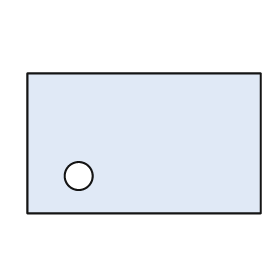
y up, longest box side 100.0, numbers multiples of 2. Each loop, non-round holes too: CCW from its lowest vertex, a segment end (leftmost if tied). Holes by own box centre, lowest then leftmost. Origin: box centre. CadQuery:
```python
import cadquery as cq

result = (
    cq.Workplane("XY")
    .moveTo(-50.0, -30.0)
    .lineTo(50.0, -30.0)
    .lineTo(50.0, 30.0)
    .lineTo(-50.0, 30.0)
    .close()
    .moveTo(-28.0, -14.0)
    .circle(6.0)
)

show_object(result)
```